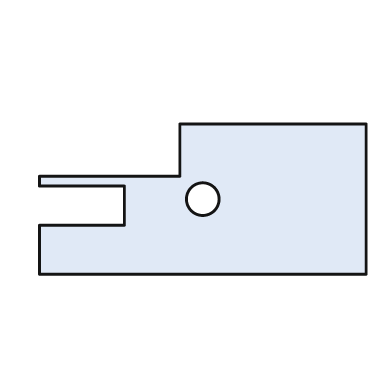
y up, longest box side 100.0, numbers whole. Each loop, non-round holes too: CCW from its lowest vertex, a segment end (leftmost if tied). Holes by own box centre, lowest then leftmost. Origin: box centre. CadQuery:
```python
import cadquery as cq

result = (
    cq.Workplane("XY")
    .moveTo(-50.0, -23.0)
    .lineTo(50.0, -23.0)
    .lineTo(50.0, 23.0)
    .lineTo(-7.0, 23.0)
    .lineTo(-7.0, 7.0)
    .lineTo(-50.0, 7.0)
    .lineTo(-50.0, 4.0)
    .lineTo(-24.0, 4.0)
    .lineTo(-24.0, -8.0)
    .lineTo(-50.0, -8.0)
    .close()
    .moveTo(0.0, 0.0)
    .circle(5.0)
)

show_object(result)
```